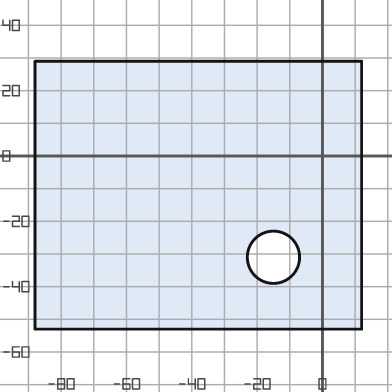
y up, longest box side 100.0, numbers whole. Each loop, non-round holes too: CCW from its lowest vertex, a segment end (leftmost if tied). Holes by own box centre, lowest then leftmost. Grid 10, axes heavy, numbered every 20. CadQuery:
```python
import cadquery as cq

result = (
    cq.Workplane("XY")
    .moveTo(-88.0, -53.0)
    .lineTo(12.0, -53.0)
    .lineTo(12.0, 29.0)
    .lineTo(-88.0, 29.0)
    .close()
    .moveTo(-15.0, -31.0)
    .circle(8.0)
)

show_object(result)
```